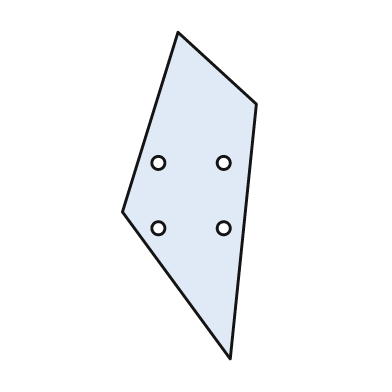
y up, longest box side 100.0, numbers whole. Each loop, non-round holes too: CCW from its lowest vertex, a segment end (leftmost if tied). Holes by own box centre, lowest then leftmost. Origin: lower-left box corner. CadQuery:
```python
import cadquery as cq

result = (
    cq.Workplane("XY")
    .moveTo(33.0, 0.0)
    .lineTo(41.0, 78.0)
    .lineTo(17.0, 100.0)
    .lineTo(0.0, 45.0)
    .close()
    .moveTo(11.0, 40.0)
    .circle(2.0)
    .moveTo(31.0, 40.0)
    .circle(2.0)
    .moveTo(11.0, 60.0)
    .circle(2.0)
    .moveTo(31.0, 60.0)
    .circle(2.0)
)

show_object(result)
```